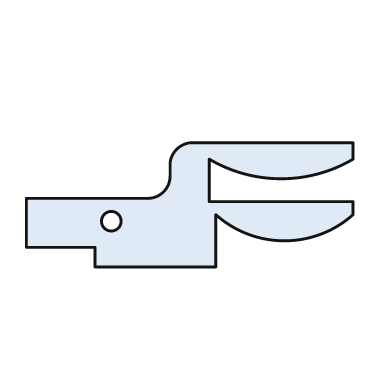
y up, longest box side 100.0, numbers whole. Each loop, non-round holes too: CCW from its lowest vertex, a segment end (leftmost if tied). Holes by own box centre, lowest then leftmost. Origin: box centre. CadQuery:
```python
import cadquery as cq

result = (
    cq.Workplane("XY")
    .moveTo(-29.0, -19.0)
    .lineTo(8.0, -19.0)
    .lineTo(8.0, -3.0)
    .threePointArc((29.0, -11.0), (50.0, -3.0))
    .lineTo(50.0, 1.0)
    .lineTo(6.0, 1.0)
    .lineTo(6.0, 14.0)
    .threePointArc((28.0, 8.0), (50.0, 14.0))
    .lineTo(50.0, 19.0)
    .lineTo(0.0, 19.0)
    .threePointArc((-4.0, 17.0), (-6.0, 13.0))
    .lineTo(-6.0, 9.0)
    .threePointArc((-8.0, 4.0), (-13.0, 2.0))
    .lineTo(-50.0, 2.0)
    .lineTo(-50.0, -13.0)
    .lineTo(-29.0, -13.0)
    .close()
    .moveTo(-24.0, -5.0)
    .circle(3.0)
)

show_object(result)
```